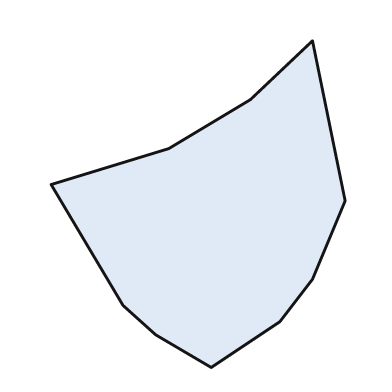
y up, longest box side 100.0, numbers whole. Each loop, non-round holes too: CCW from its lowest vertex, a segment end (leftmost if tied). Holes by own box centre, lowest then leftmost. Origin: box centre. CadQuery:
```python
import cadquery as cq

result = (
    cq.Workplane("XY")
    .moveTo(4.0, -50.0)
    .lineTo(25.0, -36.0)
    .lineTo(35.0, -23.0)
    .lineTo(45.0, 1.0)
    .lineTo(35.0, 50.0)
    .lineTo(16.0, 32.0)
    .lineTo(-9.0, 17.0)
    .lineTo(-45.0, 6.0)
    .lineTo(-23.0, -31.0)
    .lineTo(-13.0, -40.0)
    .close()
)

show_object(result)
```